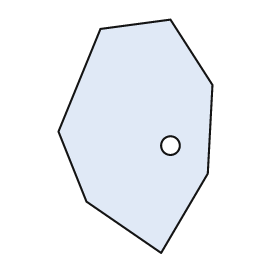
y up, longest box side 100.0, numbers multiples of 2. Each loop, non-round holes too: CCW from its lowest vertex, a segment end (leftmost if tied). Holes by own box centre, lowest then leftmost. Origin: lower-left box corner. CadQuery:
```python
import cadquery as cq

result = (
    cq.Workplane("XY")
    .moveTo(44.0, 0.0)
    .lineTo(64.0, 34.0)
    .lineTo(66.0, 72.0)
    .lineTo(48.0, 100.0)
    .lineTo(18.0, 96.0)
    .lineTo(0.0, 52.0)
    .lineTo(12.0, 22.0)
    .close()
    .moveTo(48.0, 46.0)
    .circle(4.0)
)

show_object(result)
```